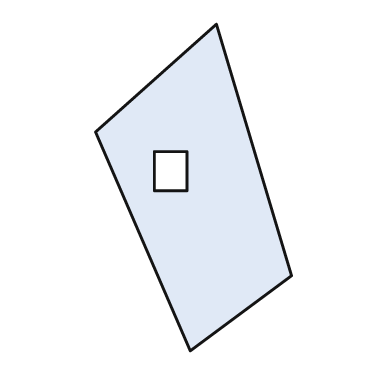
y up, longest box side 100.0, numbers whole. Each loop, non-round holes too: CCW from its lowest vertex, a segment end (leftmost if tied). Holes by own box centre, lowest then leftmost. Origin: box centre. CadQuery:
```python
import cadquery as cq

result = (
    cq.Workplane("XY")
    .moveTo(-1.0, -50.0)
    .lineTo(30.0, -27.0)
    .lineTo(7.0, 50.0)
    .lineTo(-30.0, 17.0)
    .close()
    .moveTo(-12.0, -1.0)
    .lineTo(-2.0, -1.0)
    .lineTo(-2.0, 11.0)
    .lineTo(-12.0, 11.0)
    .close()
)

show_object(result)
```